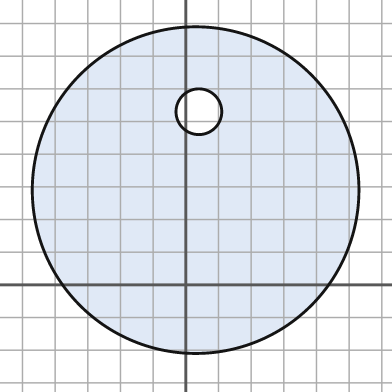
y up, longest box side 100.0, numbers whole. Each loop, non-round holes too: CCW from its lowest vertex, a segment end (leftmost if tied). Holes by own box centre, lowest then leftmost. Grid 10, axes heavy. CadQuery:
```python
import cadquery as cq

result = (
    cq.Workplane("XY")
    .moveTo(3.0, 29.0)
    .circle(50.0)
    .moveTo(4.0, 53.0)
    .circle(7.0)
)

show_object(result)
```